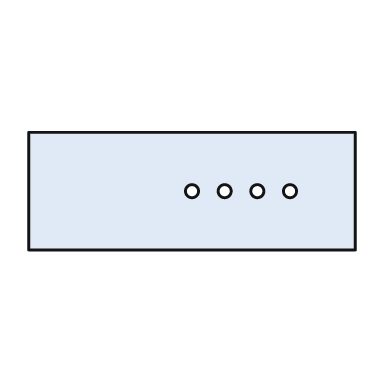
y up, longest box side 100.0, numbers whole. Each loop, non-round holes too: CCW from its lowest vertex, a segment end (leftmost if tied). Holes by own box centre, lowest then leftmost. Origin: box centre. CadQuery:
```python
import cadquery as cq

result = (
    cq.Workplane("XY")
    .moveTo(-50.0, -18.0)
    .lineTo(50.0, -18.0)
    .lineTo(50.0, 18.0)
    .lineTo(-50.0, 18.0)
    .close()
    .moveTo(0.0, 0.0)
    .circle(2.0)
    .moveTo(10.0, 0.0)
    .circle(2.0)
    .moveTo(20.0, 0.0)
    .circle(2.0)
    .moveTo(30.0, 0.0)
    .circle(2.0)
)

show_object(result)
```